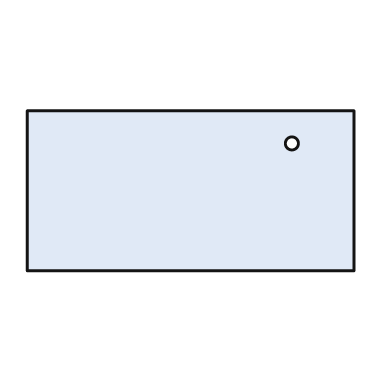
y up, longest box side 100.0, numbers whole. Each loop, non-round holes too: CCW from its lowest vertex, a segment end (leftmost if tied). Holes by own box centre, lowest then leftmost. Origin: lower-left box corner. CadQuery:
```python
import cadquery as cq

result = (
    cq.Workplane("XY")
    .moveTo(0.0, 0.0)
    .lineTo(100.0, 0.0)
    .lineTo(100.0, 49.0)
    .lineTo(0.0, 49.0)
    .close()
    .moveTo(81.0, 39.0)
    .circle(2.0)
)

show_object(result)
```